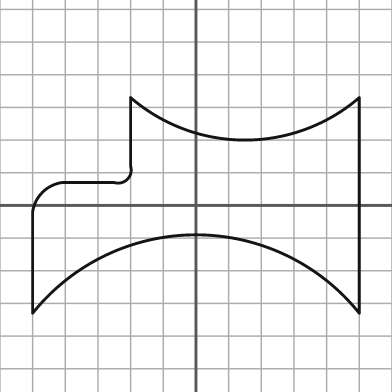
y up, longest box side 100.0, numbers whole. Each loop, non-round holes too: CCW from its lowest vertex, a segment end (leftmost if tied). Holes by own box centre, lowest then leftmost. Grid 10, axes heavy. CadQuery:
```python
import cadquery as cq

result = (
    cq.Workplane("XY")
    .moveTo(-50.0, -33.0)
    .threePointArc((0.0, -9.0), (50.0, -33.0))
    .lineTo(50.0, 33.0)
    .threePointArc((15.0, 20.0), (-20.0, 33.0))
    .lineTo(-20.0, 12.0)
    .threePointArc((-21.0, 8.0), (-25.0, 7.0))
    .lineTo(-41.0, 7.0)
    .threePointArc((-47.0, 4.0), (-50.0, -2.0))
    .close()
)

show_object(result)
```